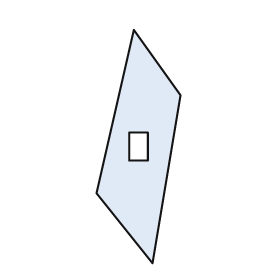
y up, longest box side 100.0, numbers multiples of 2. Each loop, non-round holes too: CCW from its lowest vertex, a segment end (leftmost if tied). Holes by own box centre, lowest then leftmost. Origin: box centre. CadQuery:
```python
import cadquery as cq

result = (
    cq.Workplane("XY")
    .moveTo(6.0, -50.0)
    .lineTo(18.0, 22.0)
    .lineTo(-2.0, 50.0)
    .lineTo(-18.0, -20.0)
    .close()
    .moveTo(-4.0, -6.0)
    .lineTo(4.0, -6.0)
    .lineTo(4.0, 6.0)
    .lineTo(-4.0, 6.0)
    .close()
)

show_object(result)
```